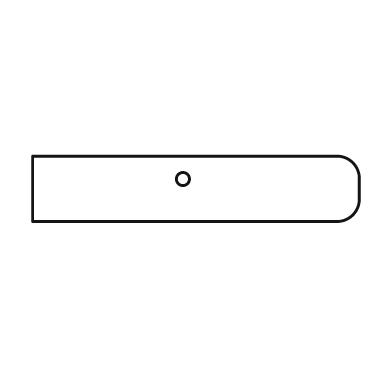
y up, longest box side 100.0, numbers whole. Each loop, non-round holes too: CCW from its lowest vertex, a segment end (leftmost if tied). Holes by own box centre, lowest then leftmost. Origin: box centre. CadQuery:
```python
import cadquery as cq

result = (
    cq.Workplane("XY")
    .moveTo(-50.0, -10.0)
    .lineTo(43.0, -10.0)
    .threePointArc((48.0, -8.0), (50.0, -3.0))
    .lineTo(50.0, 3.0)
    .threePointArc((48.0, 8.0), (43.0, 10.0))
    .lineTo(-50.0, 10.0)
    .close()
    .moveTo(-4.0, 3.0)
    .circle(2.0)
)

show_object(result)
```